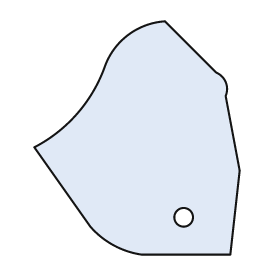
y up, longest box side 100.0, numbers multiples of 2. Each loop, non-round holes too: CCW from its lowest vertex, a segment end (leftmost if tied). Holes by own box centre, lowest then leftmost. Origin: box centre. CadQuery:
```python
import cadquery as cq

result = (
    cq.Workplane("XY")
    .moveTo(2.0, -50.0)
    .lineTo(40.0, -50.0)
    .lineTo(44.0, -14.0)
    .lineTo(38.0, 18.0)
    .threePointArc((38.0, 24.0), (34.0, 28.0))
    .lineTo(12.0, 50.0)
    .threePointArc((-4.0, 44.0), (-14.0, 30.0))
    .threePointArc((-26.0, 10.0), (-44.0, -4.0))
    .lineTo(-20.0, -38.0)
    .threePointArc((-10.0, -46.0), (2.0, -50.0))
    .close()
    .moveTo(20.0, -34.0)
    .circle(4.0)
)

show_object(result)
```